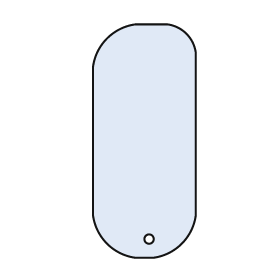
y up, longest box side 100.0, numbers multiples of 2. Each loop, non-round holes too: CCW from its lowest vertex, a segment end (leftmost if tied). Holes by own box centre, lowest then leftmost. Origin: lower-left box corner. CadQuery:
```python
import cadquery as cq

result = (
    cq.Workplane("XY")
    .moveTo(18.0, 0.0)
    .lineTo(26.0, 0.0)
    .threePointArc((38.0, 6.0), (44.0, 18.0))
    .lineTo(44.0, 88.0)
    .threePointArc((40.0, 96.0), (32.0, 100.0))
    .lineTo(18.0, 100.0)
    .threePointArc((6.0, 94.0), (0.0, 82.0))
    .lineTo(0.0, 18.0)
    .threePointArc((6.0, 6.0), (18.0, 0.0))
    .close()
    .moveTo(24.0, 8.0)
    .circle(2.0)
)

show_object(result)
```